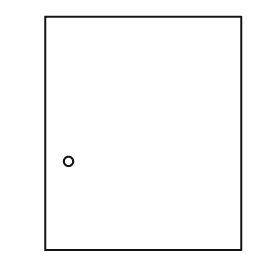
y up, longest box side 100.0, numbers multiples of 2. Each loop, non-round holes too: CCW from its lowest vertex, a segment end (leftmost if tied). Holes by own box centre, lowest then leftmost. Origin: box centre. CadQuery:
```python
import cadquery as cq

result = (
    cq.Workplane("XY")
    .moveTo(-42.0, -50.0)
    .lineTo(42.0, -50.0)
    .lineTo(42.0, 50.0)
    .lineTo(-42.0, 50.0)
    .close()
    .moveTo(-32.0, -12.0)
    .circle(2.0)
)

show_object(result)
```